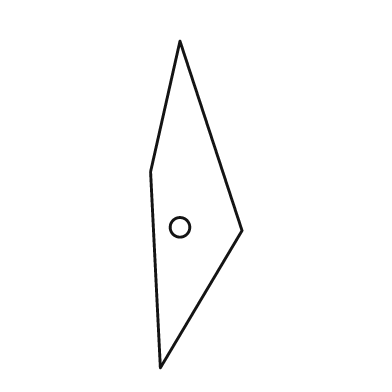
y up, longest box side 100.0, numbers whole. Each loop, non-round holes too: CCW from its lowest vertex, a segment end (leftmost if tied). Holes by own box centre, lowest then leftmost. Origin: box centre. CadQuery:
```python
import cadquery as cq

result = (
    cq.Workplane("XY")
    .moveTo(-11.0, -50.0)
    .lineTo(14.0, -8.0)
    .lineTo(-5.0, 50.0)
    .lineTo(-14.0, 10.0)
    .close()
    .moveTo(-5.0, -7.0)
    .circle(3.0)
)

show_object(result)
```